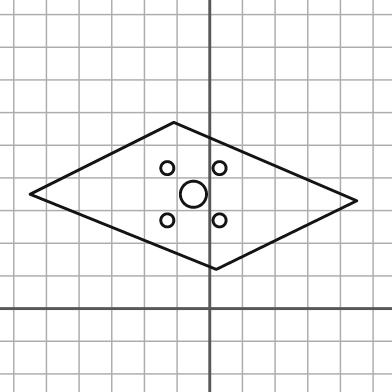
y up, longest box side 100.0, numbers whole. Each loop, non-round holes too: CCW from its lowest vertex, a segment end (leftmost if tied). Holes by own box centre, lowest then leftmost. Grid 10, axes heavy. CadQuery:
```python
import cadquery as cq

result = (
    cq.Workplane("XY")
    .moveTo(2.0, 12.0)
    .lineTo(45.0, 33.0)
    .lineTo(-11.0, 57.0)
    .lineTo(-55.0, 35.0)
    .close()
    .moveTo(-13.0, 27.0)
    .circle(2.0)
    .moveTo(3.0, 27.0)
    .circle(2.0)
    .moveTo(-5.0, 35.0)
    .circle(4.0)
    .moveTo(-13.0, 43.0)
    .circle(2.0)
    .moveTo(3.0, 43.0)
    .circle(2.0)
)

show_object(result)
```